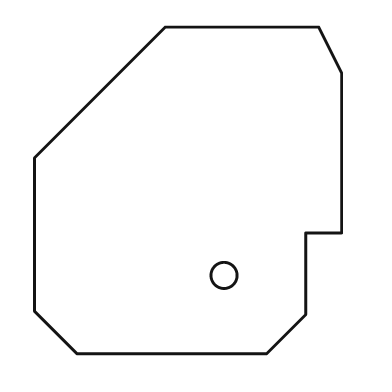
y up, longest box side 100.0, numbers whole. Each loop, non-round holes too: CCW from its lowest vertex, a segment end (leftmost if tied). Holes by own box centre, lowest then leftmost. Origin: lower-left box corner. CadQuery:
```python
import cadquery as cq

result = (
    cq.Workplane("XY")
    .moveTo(13.0, 0.0)
    .lineTo(71.0, 0.0)
    .lineTo(83.0, 12.0)
    .lineTo(83.0, 37.0)
    .lineTo(94.0, 37.0)
    .lineTo(94.0, 86.0)
    .lineTo(87.0, 100.0)
    .lineTo(40.0, 100.0)
    .lineTo(0.0, 60.0)
    .lineTo(0.0, 13.0)
    .close()
    .moveTo(58.0, 24.0)
    .circle(4.0)
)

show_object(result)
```